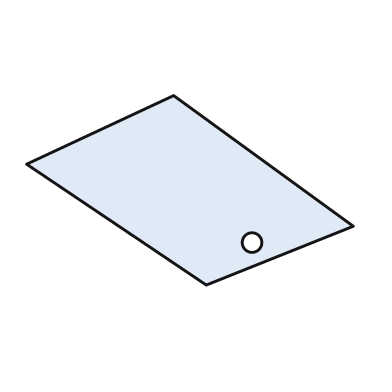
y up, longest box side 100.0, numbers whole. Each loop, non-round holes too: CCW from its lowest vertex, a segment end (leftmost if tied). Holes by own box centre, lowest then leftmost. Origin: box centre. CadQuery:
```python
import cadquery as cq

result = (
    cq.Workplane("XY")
    .moveTo(5.0, -29.0)
    .lineTo(50.0, -11.0)
    .lineTo(-5.0, 29.0)
    .lineTo(-50.0, 8.0)
    .close()
    .moveTo(19.0, -16.0)
    .circle(3.0)
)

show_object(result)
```